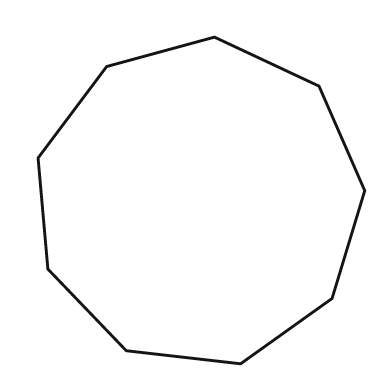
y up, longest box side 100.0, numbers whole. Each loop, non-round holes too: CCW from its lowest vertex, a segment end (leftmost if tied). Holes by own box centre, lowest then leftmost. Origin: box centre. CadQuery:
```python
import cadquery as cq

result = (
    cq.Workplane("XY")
    .moveTo(12.0, -50.0)
    .lineTo(40.0, -30.0)
    .lineTo(50.0, 3.0)
    .lineTo(36.0, 35.0)
    .lineTo(4.0, 50.0)
    .lineTo(-29.0, 41.0)
    .lineTo(-50.0, 13.0)
    .lineTo(-47.0, -21.0)
    .lineTo(-23.0, -46.0)
    .close()
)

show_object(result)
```